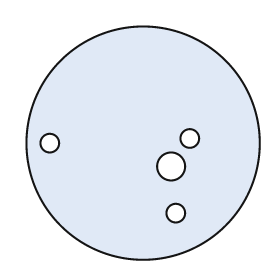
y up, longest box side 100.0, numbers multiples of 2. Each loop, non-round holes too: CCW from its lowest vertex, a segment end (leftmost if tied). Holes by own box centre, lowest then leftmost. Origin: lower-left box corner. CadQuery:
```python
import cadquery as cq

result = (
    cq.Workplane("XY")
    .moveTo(50.0, 50.0)
    .circle(50.0)
    .moveTo(64.0, 20.0)
    .circle(4.0)
    .moveTo(62.0, 40.0)
    .circle(6.0)
    .moveTo(10.0, 50.0)
    .circle(4.0)
    .moveTo(70.0, 52.0)
    .circle(4.0)
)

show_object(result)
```